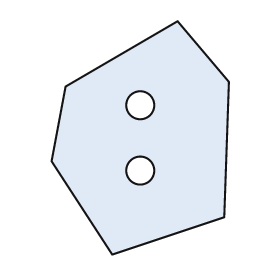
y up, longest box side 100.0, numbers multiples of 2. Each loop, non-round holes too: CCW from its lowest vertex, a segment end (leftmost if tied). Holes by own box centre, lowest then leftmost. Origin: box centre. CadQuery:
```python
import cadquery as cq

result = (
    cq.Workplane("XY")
    .moveTo(-12.0, -50.0)
    .lineTo(36.0, -34.0)
    .lineTo(38.0, 24.0)
    .lineTo(16.0, 50.0)
    .lineTo(-32.0, 22.0)
    .lineTo(-38.0, -10.0)
    .close()
    .moveTo(0.0, -14.0)
    .circle(6.0)
    .moveTo(0.0, 14.0)
    .circle(6.0)
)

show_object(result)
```